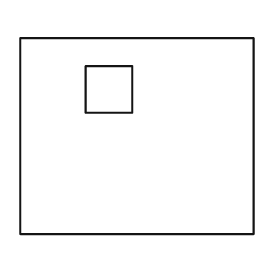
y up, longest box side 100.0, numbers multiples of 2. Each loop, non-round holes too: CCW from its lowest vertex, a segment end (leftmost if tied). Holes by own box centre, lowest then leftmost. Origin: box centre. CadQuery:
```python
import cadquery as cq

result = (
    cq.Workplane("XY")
    .moveTo(-50.0, -42.0)
    .lineTo(50.0, -42.0)
    .lineTo(50.0, 42.0)
    .lineTo(-50.0, 42.0)
    .close()
    .moveTo(-22.0, 10.0)
    .lineTo(-2.0, 10.0)
    .lineTo(-2.0, 30.0)
    .lineTo(-22.0, 30.0)
    .close()
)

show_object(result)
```